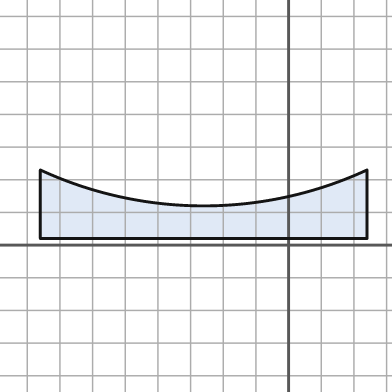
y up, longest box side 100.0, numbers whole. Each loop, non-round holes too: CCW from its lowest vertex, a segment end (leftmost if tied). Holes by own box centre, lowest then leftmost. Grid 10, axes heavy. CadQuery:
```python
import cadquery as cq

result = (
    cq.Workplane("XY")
    .moveTo(-76.0, 2.0)
    .lineTo(24.0, 2.0)
    .lineTo(24.0, 23.0)
    .threePointArc((-26.0, 12.0), (-76.0, 23.0))
    .close()
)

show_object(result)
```